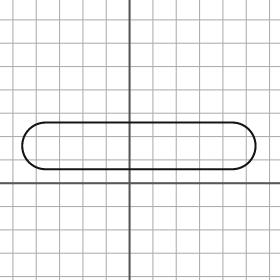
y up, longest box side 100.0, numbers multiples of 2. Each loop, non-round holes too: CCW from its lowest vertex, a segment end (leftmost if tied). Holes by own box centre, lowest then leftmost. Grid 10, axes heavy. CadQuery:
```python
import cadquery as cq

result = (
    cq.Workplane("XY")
    .moveTo(-36.0, 6.0)
    .lineTo(44.0, 6.0)
    .threePointArc((54.0, 16.0), (44.0, 26.0))
    .lineTo(-36.0, 26.0)
    .threePointArc((-46.0, 16.0), (-36.0, 6.0))
    .close()
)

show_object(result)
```